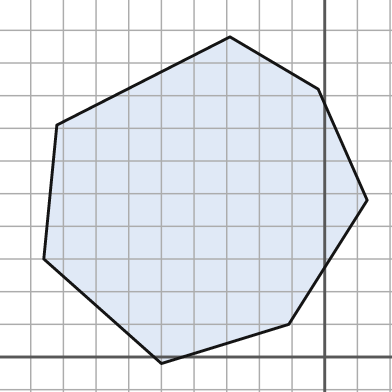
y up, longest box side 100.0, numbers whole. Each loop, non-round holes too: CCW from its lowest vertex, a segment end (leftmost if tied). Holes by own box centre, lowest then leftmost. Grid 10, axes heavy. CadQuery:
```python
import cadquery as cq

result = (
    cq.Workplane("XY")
    .moveTo(-50.0, -2.0)
    .lineTo(-11.0, 10.0)
    .lineTo(13.0, 48.0)
    .lineTo(-2.0, 82.0)
    .lineTo(-29.0, 98.0)
    .lineTo(-82.0, 71.0)
    .lineTo(-86.0, 30.0)
    .close()
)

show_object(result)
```